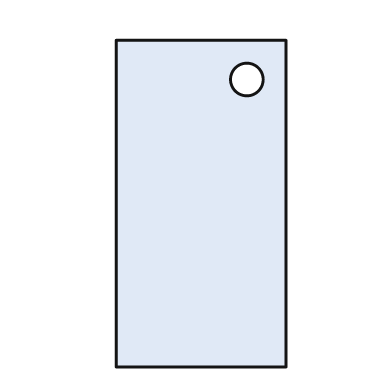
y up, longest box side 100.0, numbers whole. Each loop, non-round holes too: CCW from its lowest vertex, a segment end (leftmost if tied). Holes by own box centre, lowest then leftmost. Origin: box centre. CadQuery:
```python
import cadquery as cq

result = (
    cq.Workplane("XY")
    .moveTo(-26.0, -50.0)
    .lineTo(26.0, -50.0)
    .lineTo(26.0, 50.0)
    .lineTo(-26.0, 50.0)
    .close()
    .moveTo(14.0, 38.0)
    .circle(5.0)
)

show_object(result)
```